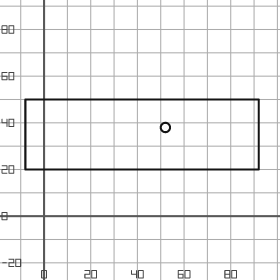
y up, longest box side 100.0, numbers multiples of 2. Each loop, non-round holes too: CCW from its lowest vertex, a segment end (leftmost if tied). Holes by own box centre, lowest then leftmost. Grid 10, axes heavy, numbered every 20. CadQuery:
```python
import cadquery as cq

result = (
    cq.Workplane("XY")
    .moveTo(-8.0, 20.0)
    .lineTo(92.0, 20.0)
    .lineTo(92.0, 50.0)
    .lineTo(-8.0, 50.0)
    .close()
    .moveTo(52.0, 38.0)
    .circle(2.0)
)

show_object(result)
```